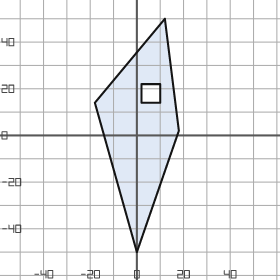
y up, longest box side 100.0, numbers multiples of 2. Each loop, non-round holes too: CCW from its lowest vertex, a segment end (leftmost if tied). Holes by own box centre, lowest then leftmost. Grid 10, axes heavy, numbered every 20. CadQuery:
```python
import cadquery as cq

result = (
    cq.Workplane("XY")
    .moveTo(0.0, -50.0)
    .lineTo(18.0, 2.0)
    .lineTo(12.0, 50.0)
    .lineTo(-18.0, 14.0)
    .close()
    .moveTo(2.0, 14.0)
    .lineTo(10.0, 14.0)
    .lineTo(10.0, 22.0)
    .lineTo(2.0, 22.0)
    .close()
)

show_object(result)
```